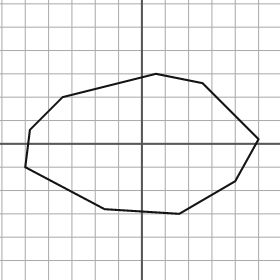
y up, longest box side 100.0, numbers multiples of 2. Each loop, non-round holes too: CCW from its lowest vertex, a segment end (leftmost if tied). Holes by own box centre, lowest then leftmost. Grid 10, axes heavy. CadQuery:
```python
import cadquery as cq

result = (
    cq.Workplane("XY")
    .moveTo(16.0, -30.0)
    .lineTo(40.0, -16.0)
    .lineTo(50.0, 2.0)
    .lineTo(26.0, 26.0)
    .lineTo(6.0, 30.0)
    .lineTo(-34.0, 20.0)
    .lineTo(-48.0, 6.0)
    .lineTo(-50.0, -10.0)
    .lineTo(-16.0, -28.0)
    .close()
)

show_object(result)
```